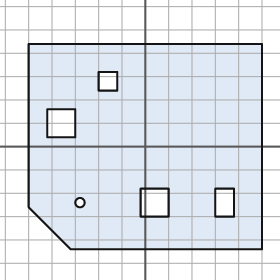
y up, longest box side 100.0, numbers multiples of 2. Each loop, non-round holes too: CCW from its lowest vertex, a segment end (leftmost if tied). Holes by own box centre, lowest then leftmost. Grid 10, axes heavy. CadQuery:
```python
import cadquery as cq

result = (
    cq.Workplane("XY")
    .moveTo(-32.0, -44.0)
    .lineTo(50.0, -44.0)
    .lineTo(50.0, 44.0)
    .lineTo(-50.0, 44.0)
    .lineTo(-50.0, -26.0)
    .close()
    .moveTo(-28.0, -24.0)
    .circle(2.0)
    .moveTo(-2.0, -30.0)
    .lineTo(10.0, -30.0)
    .lineTo(10.0, -18.0)
    .lineTo(-2.0, -18.0)
    .close()
    .moveTo(30.0, -30.0)
    .lineTo(38.0, -30.0)
    .lineTo(38.0, -18.0)
    .lineTo(30.0, -18.0)
    .close()
    .moveTo(-42.0, 4.0)
    .lineTo(-30.0, 4.0)
    .lineTo(-30.0, 16.0)
    .lineTo(-42.0, 16.0)
    .close()
    .moveTo(-20.0, 24.0)
    .lineTo(-12.0, 24.0)
    .lineTo(-12.0, 32.0)
    .lineTo(-20.0, 32.0)
    .close()
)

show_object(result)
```